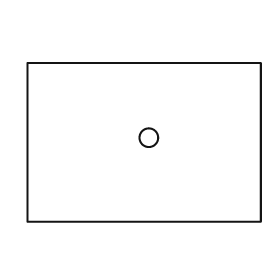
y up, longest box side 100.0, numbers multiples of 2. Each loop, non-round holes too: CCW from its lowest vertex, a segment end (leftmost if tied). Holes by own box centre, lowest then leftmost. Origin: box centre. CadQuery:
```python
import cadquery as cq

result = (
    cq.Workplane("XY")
    .moveTo(-50.0, -34.0)
    .lineTo(50.0, -34.0)
    .lineTo(50.0, 34.0)
    .lineTo(-50.0, 34.0)
    .close()
    .moveTo(2.0, 2.0)
    .circle(4.0)
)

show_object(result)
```